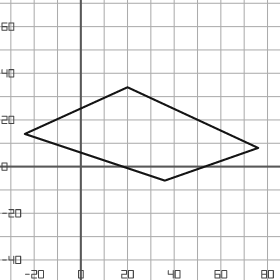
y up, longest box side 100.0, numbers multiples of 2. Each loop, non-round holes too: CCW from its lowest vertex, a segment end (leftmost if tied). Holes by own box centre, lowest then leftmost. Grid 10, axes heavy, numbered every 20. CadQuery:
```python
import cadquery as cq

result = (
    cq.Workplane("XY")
    .moveTo(36.0, -6.0)
    .lineTo(76.0, 8.0)
    .lineTo(20.0, 34.0)
    .lineTo(-24.0, 14.0)
    .close()
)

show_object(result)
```